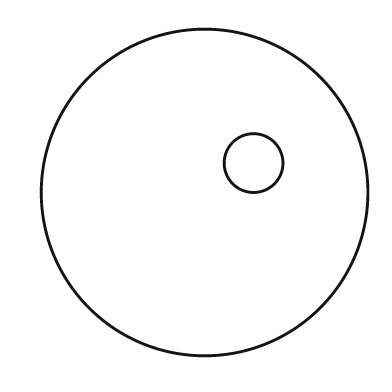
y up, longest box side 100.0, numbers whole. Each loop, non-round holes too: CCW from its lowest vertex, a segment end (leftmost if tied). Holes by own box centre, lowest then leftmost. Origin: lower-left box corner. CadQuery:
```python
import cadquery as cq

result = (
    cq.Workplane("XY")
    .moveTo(50.0, 50.0)
    .circle(50.0)
    .moveTo(65.0, 59.0)
    .circle(9.0)
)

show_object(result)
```